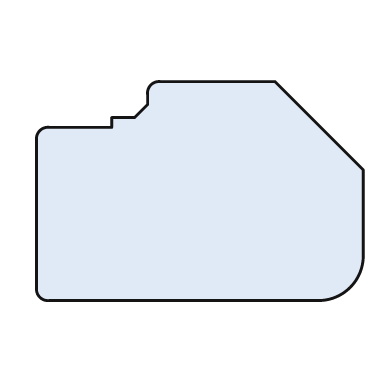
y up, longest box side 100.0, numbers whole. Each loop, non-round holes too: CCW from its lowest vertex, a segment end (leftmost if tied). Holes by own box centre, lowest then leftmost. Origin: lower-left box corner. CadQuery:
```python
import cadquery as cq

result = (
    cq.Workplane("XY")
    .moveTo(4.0, 0.0)
    .lineTo(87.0, 0.0)
    .threePointArc((96.0, 4.0), (100.0, 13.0))
    .lineTo(100.0, 40.0)
    .lineTo(73.0, 67.0)
    .lineTo(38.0, 67.0)
    .threePointArc((35.0, 66.0), (34.0, 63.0))
    .lineTo(34.0, 60.0)
    .lineTo(30.0, 56.0)
    .lineTo(23.0, 56.0)
    .lineTo(23.0, 53.0)
    .lineTo(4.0, 53.0)
    .threePointArc((1.0, 52.0), (0.0, 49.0))
    .lineTo(0.0, 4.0)
    .threePointArc((1.0, 1.0), (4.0, 0.0))
    .close()
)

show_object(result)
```